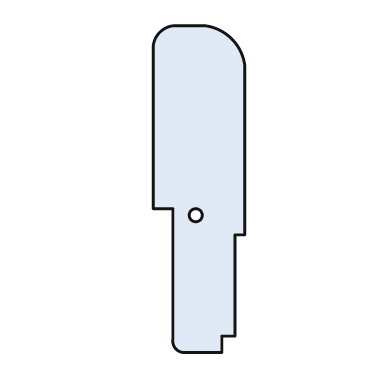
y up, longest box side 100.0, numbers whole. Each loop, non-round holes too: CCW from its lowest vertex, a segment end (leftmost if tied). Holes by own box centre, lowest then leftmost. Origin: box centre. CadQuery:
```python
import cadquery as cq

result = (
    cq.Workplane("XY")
    .moveTo(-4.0, -50.0)
    .lineTo(7.0, -50.0)
    .lineTo(7.0, -45.0)
    .lineTo(11.0, -45.0)
    .lineTo(11.0, -14.0)
    .lineTo(14.0, -14.0)
    .lineTo(14.0, 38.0)
    .threePointArc((10.0, 46.0), (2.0, 50.0))
    .lineTo(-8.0, 50.0)
    .threePointArc((-12.0, 48.0), (-14.0, 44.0))
    .lineTo(-14.0, -6.0)
    .lineTo(-8.0, -6.0)
    .lineTo(-8.0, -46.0)
    .threePointArc((-7.0, -49.0), (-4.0, -50.0))
    .close()
    .moveTo(-1.0, -8.0)
    .circle(2.0)
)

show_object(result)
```